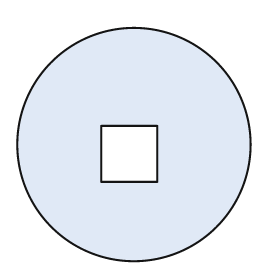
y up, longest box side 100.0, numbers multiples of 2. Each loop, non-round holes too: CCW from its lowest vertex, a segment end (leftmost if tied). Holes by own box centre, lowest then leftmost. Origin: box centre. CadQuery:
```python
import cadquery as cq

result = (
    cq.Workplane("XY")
    .moveTo(0.0, 0.0)
    .circle(50.0)
    .moveTo(-14.0, -16.0)
    .lineTo(10.0, -16.0)
    .lineTo(10.0, 8.0)
    .lineTo(-14.0, 8.0)
    .close()
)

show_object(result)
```